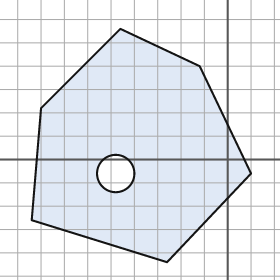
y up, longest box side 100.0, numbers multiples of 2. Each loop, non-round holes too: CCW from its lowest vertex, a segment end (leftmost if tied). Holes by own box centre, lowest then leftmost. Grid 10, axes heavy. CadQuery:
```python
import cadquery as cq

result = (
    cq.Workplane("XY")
    .moveTo(-26.0, -44.0)
    .lineTo(10.0, -6.0)
    .lineTo(-12.0, 40.0)
    .lineTo(-46.0, 56.0)
    .lineTo(-80.0, 22.0)
    .lineTo(-84.0, -26.0)
    .close()
    .moveTo(-48.0, -6.0)
    .circle(8.0)
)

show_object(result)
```